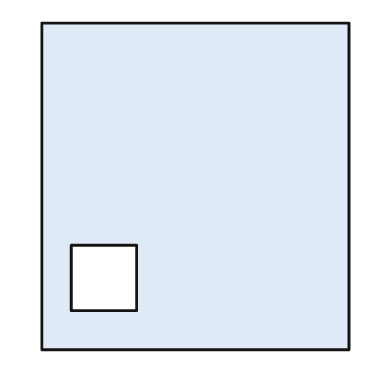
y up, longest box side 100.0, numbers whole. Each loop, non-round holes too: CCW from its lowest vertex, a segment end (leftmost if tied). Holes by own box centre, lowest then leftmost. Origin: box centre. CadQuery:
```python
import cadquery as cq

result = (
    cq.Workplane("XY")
    .moveTo(-47.0, -50.0)
    .lineTo(47.0, -50.0)
    .lineTo(47.0, 50.0)
    .lineTo(-47.0, 50.0)
    .close()
    .moveTo(-38.0, -38.0)
    .lineTo(-18.0, -38.0)
    .lineTo(-18.0, -18.0)
    .lineTo(-38.0, -18.0)
    .close()
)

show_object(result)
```